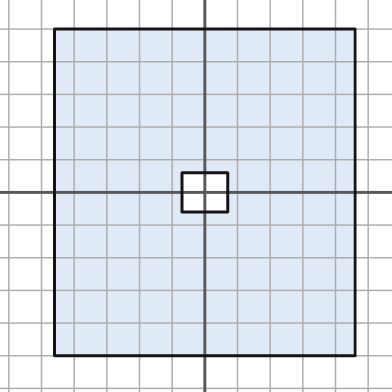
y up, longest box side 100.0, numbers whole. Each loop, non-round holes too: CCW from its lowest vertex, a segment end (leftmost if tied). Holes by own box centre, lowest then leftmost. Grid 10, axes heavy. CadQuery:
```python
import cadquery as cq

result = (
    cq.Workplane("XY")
    .moveTo(-46.0, -50.0)
    .lineTo(46.0, -50.0)
    .lineTo(46.0, 50.0)
    .lineTo(-46.0, 50.0)
    .close()
    .moveTo(-7.0, -6.0)
    .lineTo(7.0, -6.0)
    .lineTo(7.0, 6.0)
    .lineTo(-7.0, 6.0)
    .close()
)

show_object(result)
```